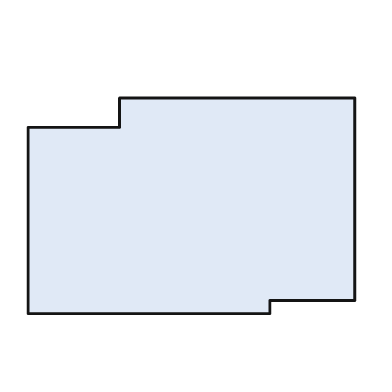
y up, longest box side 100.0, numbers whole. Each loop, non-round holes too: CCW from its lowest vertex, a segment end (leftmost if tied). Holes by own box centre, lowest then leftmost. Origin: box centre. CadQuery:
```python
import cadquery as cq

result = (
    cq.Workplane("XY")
    .moveTo(-50.0, -33.0)
    .lineTo(24.0, -33.0)
    .lineTo(24.0, -29.0)
    .lineTo(50.0, -29.0)
    .lineTo(50.0, 33.0)
    .lineTo(-22.0, 33.0)
    .lineTo(-22.0, 24.0)
    .lineTo(-50.0, 24.0)
    .close()
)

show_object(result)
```